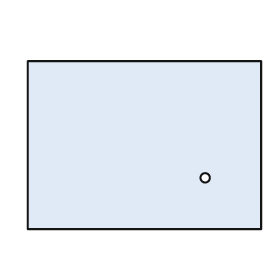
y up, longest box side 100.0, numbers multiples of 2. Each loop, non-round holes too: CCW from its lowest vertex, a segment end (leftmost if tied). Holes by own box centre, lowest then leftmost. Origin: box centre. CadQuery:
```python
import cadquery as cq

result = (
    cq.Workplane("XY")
    .moveTo(-50.0, -36.0)
    .lineTo(50.0, -36.0)
    .lineTo(50.0, 36.0)
    .lineTo(-50.0, 36.0)
    .close()
    .moveTo(26.0, -14.0)
    .circle(2.0)
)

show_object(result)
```